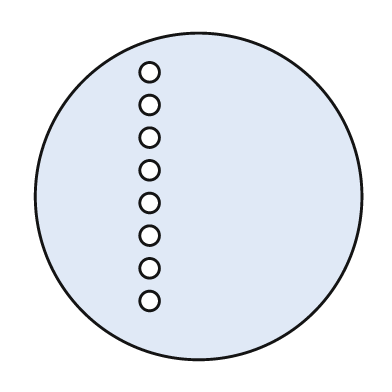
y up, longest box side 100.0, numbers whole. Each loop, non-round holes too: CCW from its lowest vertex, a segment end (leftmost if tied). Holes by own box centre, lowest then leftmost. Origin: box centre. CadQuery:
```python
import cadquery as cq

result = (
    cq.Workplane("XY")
    .moveTo(0.0, 0.0)
    .circle(50.0)
    .moveTo(-15.0, -32.0)
    .circle(3.0)
    .moveTo(-15.0, -22.0)
    .circle(3.0)
    .moveTo(-15.0, -12.0)
    .circle(3.0)
    .moveTo(-15.0, -2.0)
    .circle(3.0)
    .moveTo(-15.0, 8.0)
    .circle(3.0)
    .moveTo(-15.0, 18.0)
    .circle(3.0)
    .moveTo(-15.0, 28.0)
    .circle(3.0)
    .moveTo(-15.0, 38.0)
    .circle(3.0)
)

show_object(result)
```